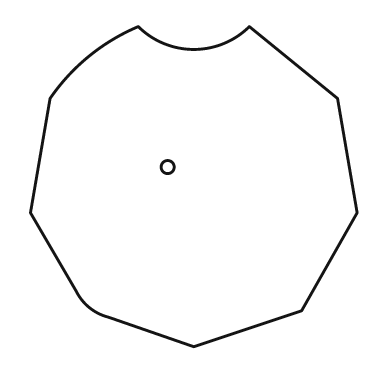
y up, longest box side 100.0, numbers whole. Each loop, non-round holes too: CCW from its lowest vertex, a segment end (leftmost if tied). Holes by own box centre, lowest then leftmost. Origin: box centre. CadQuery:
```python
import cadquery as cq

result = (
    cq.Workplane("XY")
    .moveTo(0.0, -49.0)
    .lineTo(33.0, -38.0)
    .lineTo(50.0, -8.0)
    .lineTo(44.0, 27.0)
    .lineTo(17.0, 49.0)
    .threePointArc((0.0, 42.0), (-17.0, 49.0))
    .threePointArc((-32.0, 40.0), (-44.0, 27.0))
    .lineTo(-50.0, -8.0)
    .lineTo(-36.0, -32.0)
    .threePointArc((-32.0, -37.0), (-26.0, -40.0))
    .close()
    .moveTo(-8.0, 6.0)
    .circle(2.0)
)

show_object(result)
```